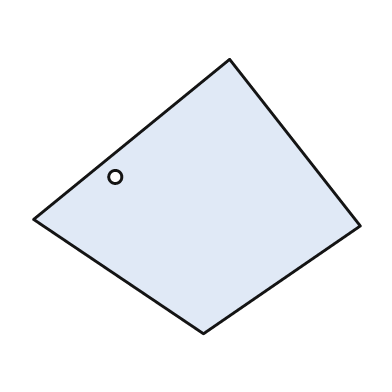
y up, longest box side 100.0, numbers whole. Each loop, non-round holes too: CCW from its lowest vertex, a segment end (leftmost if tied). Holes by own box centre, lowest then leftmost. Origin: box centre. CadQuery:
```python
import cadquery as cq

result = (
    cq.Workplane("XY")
    .moveTo(2.0, -42.0)
    .lineTo(50.0, -9.0)
    .lineTo(10.0, 42.0)
    .lineTo(-50.0, -7.0)
    .close()
    .moveTo(-25.0, 6.0)
    .circle(2.0)
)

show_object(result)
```